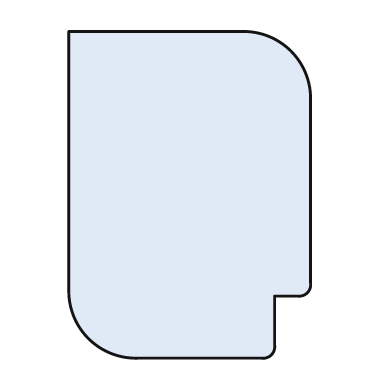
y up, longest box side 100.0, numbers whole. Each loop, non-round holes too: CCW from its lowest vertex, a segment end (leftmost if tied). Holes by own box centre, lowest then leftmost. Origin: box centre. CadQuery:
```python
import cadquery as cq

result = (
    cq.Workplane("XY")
    .moveTo(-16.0, -50.0)
    .lineTo(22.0, -50.0)
    .threePointArc((25.0, -49.0), (26.0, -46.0))
    .lineTo(26.0, -31.0)
    .lineTo(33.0, -31.0)
    .threePointArc((36.0, -30.0), (37.0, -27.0))
    .lineTo(37.0, 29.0)
    .threePointArc((31.0, 44.0), (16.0, 50.0))
    .lineTo(-37.0, 50.0)
    .lineTo(-37.0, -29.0)
    .threePointArc((-31.0, -44.0), (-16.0, -50.0))
    .close()
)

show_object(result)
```